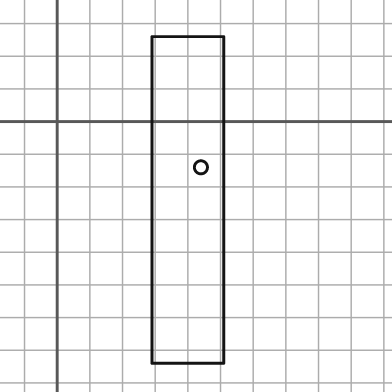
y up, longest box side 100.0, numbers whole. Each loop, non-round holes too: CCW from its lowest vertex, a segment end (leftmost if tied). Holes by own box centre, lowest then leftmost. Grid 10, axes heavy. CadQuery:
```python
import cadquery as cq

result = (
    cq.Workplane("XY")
    .moveTo(29.0, -74.0)
    .lineTo(51.0, -74.0)
    .lineTo(51.0, 26.0)
    .lineTo(29.0, 26.0)
    .close()
    .moveTo(44.0, -14.0)
    .circle(2.0)
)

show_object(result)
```